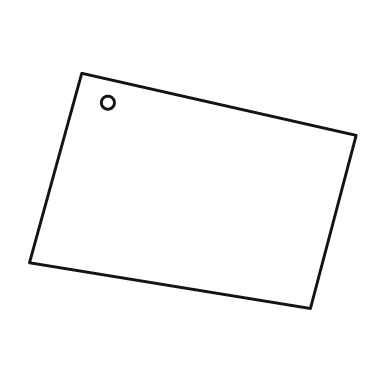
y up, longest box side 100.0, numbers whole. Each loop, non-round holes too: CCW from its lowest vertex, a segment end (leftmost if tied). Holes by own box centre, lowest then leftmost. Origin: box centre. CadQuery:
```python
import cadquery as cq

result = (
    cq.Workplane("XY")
    .moveTo(36.0, -36.0)
    .lineTo(50.0, 17.0)
    .lineTo(-34.0, 36.0)
    .lineTo(-50.0, -22.0)
    .close()
    .moveTo(-26.0, 27.0)
    .circle(2.0)
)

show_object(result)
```